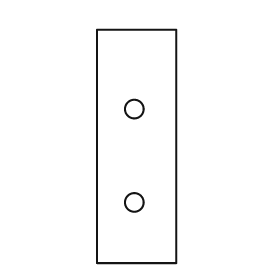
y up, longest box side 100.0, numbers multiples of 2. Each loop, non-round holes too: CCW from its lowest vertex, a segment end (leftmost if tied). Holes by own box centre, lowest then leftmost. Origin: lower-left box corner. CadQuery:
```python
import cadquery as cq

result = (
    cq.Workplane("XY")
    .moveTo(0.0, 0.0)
    .lineTo(34.0, 0.0)
    .lineTo(34.0, 100.0)
    .lineTo(0.0, 100.0)
    .close()
    .moveTo(16.0, 26.0)
    .circle(4.0)
    .moveTo(16.0, 66.0)
    .circle(4.0)
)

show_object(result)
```